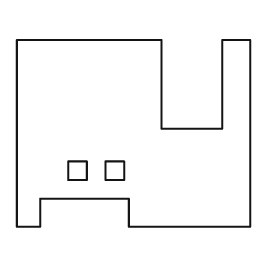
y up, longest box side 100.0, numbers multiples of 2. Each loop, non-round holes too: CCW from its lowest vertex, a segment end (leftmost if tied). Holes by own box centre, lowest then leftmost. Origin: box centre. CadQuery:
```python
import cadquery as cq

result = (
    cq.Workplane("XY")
    .moveTo(-50.0, -40.0)
    .lineTo(-40.0, -40.0)
    .lineTo(-40.0, -28.0)
    .lineTo(-2.0, -28.0)
    .lineTo(-2.0, -40.0)
    .lineTo(50.0, -40.0)
    .lineTo(50.0, 40.0)
    .lineTo(38.0, 40.0)
    .lineTo(38.0, 2.0)
    .lineTo(12.0, 2.0)
    .lineTo(12.0, 40.0)
    .lineTo(-50.0, 40.0)
    .close()
    .moveTo(-28.0, -20.0)
    .lineTo(-20.0, -20.0)
    .lineTo(-20.0, -12.0)
    .lineTo(-28.0, -12.0)
    .close()
    .moveTo(-12.0, -20.0)
    .lineTo(-4.0, -20.0)
    .lineTo(-4.0, -12.0)
    .lineTo(-12.0, -12.0)
    .close()
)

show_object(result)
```